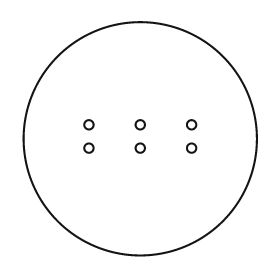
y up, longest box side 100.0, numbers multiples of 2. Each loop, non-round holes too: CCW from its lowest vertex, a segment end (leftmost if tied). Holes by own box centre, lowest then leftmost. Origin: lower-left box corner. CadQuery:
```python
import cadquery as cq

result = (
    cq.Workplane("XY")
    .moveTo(50.0, 50.0)
    .circle(50.0)
    .moveTo(28.0, 46.0)
    .circle(2.0)
    .moveTo(50.0, 46.0)
    .circle(2.0)
    .moveTo(72.0, 46.0)
    .circle(2.0)
    .moveTo(28.0, 56.0)
    .circle(2.0)
    .moveTo(50.0, 56.0)
    .circle(2.0)
    .moveTo(72.0, 56.0)
    .circle(2.0)
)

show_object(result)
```